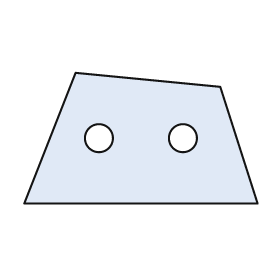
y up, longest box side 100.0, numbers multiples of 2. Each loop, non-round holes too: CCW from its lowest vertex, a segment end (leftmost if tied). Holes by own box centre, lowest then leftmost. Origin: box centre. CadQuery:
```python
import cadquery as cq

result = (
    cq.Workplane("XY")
    .moveTo(-50.0, -28.0)
    .lineTo(50.0, -28.0)
    .lineTo(34.0, 22.0)
    .lineTo(-28.0, 28.0)
    .close()
    .moveTo(-18.0, 0.0)
    .circle(6.0)
    .moveTo(18.0, 0.0)
    .circle(6.0)
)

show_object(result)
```